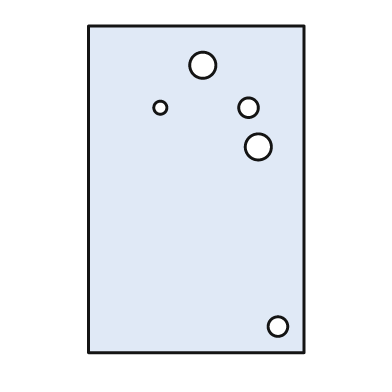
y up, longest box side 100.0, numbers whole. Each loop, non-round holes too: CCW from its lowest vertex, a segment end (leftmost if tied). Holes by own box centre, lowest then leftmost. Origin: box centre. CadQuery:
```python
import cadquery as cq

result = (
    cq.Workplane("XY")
    .moveTo(-33.0, -50.0)
    .lineTo(33.0, -50.0)
    .lineTo(33.0, 50.0)
    .lineTo(-33.0, 50.0)
    .close()
    .moveTo(25.0, -42.0)
    .circle(3.0)
    .moveTo(19.0, 13.0)
    .circle(4.0)
    .moveTo(-11.0, 25.0)
    .circle(2.0)
    .moveTo(16.0, 25.0)
    .circle(3.0)
    .moveTo(2.0, 38.0)
    .circle(4.0)
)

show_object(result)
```